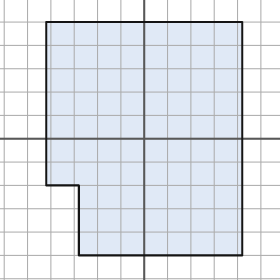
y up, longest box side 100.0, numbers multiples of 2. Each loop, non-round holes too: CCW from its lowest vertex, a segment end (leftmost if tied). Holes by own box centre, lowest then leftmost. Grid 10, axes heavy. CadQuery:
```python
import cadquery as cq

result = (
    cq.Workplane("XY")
    .moveTo(-28.0, -50.0)
    .lineTo(42.0, -50.0)
    .lineTo(42.0, 50.0)
    .lineTo(-42.0, 50.0)
    .lineTo(-42.0, -20.0)
    .lineTo(-28.0, -20.0)
    .close()
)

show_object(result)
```